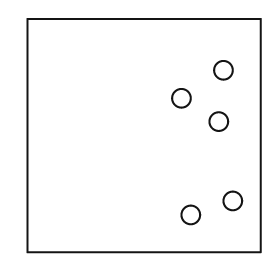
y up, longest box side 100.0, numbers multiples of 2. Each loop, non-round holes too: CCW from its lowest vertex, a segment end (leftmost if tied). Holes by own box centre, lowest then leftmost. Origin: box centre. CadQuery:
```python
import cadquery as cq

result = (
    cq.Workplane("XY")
    .moveTo(-50.0, -50.0)
    .lineTo(50.0, -50.0)
    .lineTo(50.0, 50.0)
    .lineTo(-50.0, 50.0)
    .close()
    .moveTo(20.0, -34.0)
    .circle(4.0)
    .moveTo(38.0, -28.0)
    .circle(4.0)
    .moveTo(32.0, 6.0)
    .circle(4.0)
    .moveTo(16.0, 16.0)
    .circle(4.0)
    .moveTo(34.0, 28.0)
    .circle(4.0)
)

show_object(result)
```